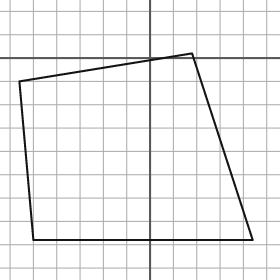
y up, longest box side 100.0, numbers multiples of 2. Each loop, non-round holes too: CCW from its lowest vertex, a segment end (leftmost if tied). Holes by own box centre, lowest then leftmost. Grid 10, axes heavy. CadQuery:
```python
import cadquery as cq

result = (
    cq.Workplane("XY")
    .moveTo(-50.0, -78.0)
    .lineTo(44.0, -78.0)
    .lineTo(18.0, 2.0)
    .lineTo(-56.0, -10.0)
    .close()
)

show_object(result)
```